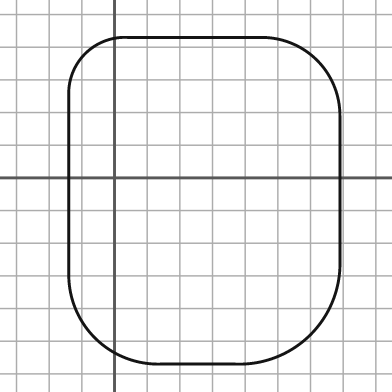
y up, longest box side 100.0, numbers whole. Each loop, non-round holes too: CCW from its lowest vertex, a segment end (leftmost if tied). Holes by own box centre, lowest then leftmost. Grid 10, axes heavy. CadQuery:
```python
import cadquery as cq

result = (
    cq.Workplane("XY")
    .moveTo(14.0, -57.0)
    .lineTo(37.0, -57.0)
    .threePointArc((60.0, -48.0), (69.0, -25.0))
    .lineTo(69.0, 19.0)
    .threePointArc((62.0, 36.0), (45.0, 43.0))
    .lineTo(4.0, 43.0)
    .threePointArc((-9.0, 38.0), (-14.0, 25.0))
    .lineTo(-14.0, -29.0)
    .threePointArc((-6.0, -49.0), (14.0, -57.0))
    .close()
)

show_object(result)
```